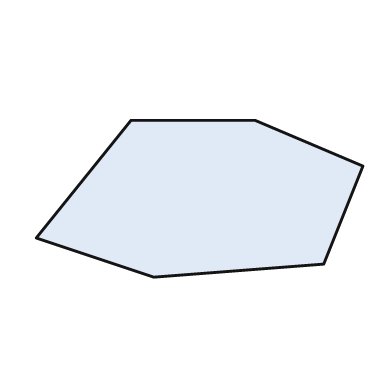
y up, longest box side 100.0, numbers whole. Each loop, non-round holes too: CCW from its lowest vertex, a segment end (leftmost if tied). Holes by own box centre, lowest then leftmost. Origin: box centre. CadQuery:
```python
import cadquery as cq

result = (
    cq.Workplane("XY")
    .moveTo(-14.0, -24.0)
    .lineTo(38.0, -20.0)
    .lineTo(50.0, 10.0)
    .lineTo(17.0, 24.0)
    .lineTo(-21.0, 24.0)
    .lineTo(-50.0, -12.0)
    .close()
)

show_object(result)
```